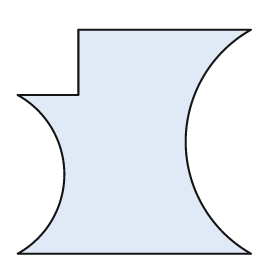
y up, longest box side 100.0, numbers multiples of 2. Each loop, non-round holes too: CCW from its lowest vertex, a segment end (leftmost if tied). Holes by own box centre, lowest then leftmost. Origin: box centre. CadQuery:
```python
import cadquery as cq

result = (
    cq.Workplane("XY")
    .moveTo(-50.0, -48.0)
    .lineTo(50.0, -48.0)
    .threePointArc((22.0, 0.0), (50.0, 48.0))
    .lineTo(-24.0, 48.0)
    .lineTo(-24.0, 20.0)
    .lineTo(-50.0, 20.0)
    .threePointArc((-30.0, -14.0), (-50.0, -48.0))
    .close()
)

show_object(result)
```